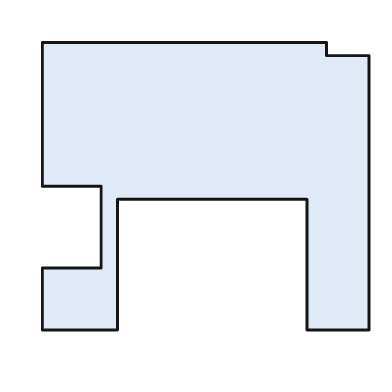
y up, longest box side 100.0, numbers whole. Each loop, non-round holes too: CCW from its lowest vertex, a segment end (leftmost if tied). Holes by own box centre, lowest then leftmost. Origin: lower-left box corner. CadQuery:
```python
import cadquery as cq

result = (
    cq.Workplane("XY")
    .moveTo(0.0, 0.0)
    .lineTo(23.0, 0.0)
    .lineTo(23.0, 40.0)
    .lineTo(81.0, 40.0)
    .lineTo(81.0, 0.0)
    .lineTo(100.0, 0.0)
    .lineTo(100.0, 84.0)
    .lineTo(87.0, 84.0)
    .lineTo(87.0, 88.0)
    .lineTo(0.0, 88.0)
    .lineTo(0.0, 44.0)
    .lineTo(18.0, 44.0)
    .lineTo(18.0, 19.0)
    .lineTo(0.0, 19.0)
    .close()
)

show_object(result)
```